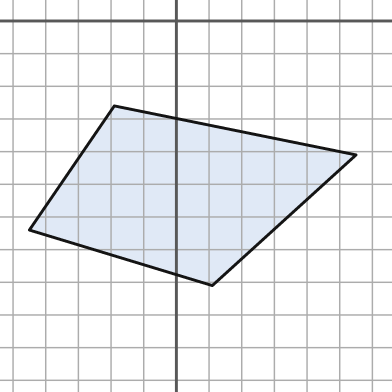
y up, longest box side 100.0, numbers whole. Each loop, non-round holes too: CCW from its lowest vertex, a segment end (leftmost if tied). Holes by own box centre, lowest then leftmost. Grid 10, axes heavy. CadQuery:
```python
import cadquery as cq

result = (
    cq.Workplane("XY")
    .moveTo(11.0, -81.0)
    .lineTo(55.0, -41.0)
    .lineTo(-19.0, -26.0)
    .lineTo(-45.0, -64.0)
    .close()
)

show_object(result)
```